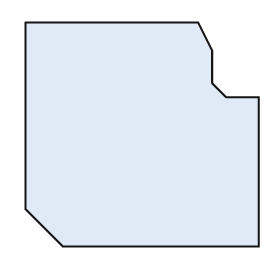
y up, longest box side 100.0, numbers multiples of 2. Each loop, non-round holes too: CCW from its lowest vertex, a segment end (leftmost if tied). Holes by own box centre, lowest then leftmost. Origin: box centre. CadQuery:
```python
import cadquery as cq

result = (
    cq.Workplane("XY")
    .moveTo(-34.0, -48.0)
    .lineTo(50.0, -48.0)
    .lineTo(50.0, 16.0)
    .lineTo(36.0, 16.0)
    .lineTo(30.0, 22.0)
    .lineTo(30.0, 36.0)
    .lineTo(24.0, 48.0)
    .lineTo(-50.0, 48.0)
    .lineTo(-50.0, -32.0)
    .close()
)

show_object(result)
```